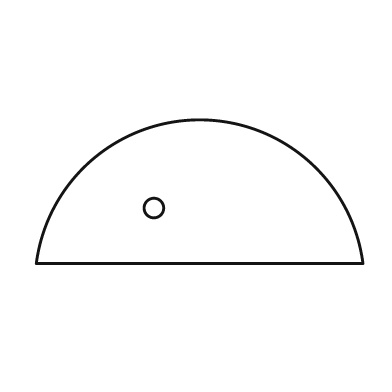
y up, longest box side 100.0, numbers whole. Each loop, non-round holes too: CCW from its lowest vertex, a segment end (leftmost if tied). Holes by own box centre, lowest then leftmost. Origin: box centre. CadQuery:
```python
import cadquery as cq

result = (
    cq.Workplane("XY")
    .moveTo(-50.0, -22.0)
    .lineTo(50.0, -22.0)
    .threePointArc((0.0, 22.0), (-50.0, -22.0))
    .close()
    .moveTo(-14.0, -5.0)
    .circle(3.0)
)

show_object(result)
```